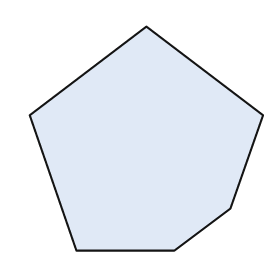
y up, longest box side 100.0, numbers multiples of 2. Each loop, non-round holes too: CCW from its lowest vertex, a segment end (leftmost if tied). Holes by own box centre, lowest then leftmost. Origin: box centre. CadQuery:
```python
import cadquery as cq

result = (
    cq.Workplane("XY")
    .moveTo(-30.0, -48.0)
    .lineTo(12.0, -48.0)
    .lineTo(36.0, -30.0)
    .lineTo(50.0, 10.0)
    .lineTo(0.0, 48.0)
    .lineTo(-50.0, 10.0)
    .close()
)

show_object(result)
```